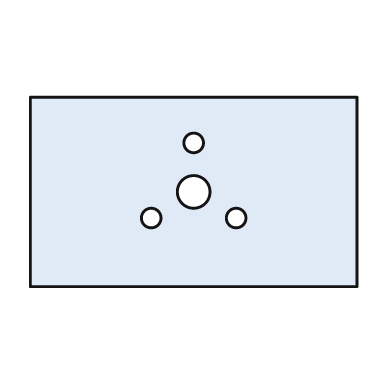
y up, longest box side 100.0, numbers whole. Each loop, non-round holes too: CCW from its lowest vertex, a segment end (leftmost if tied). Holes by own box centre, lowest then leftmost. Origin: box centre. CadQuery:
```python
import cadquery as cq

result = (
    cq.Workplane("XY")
    .moveTo(-50.0, -29.0)
    .lineTo(50.0, -29.0)
    .lineTo(50.0, 29.0)
    .lineTo(-50.0, 29.0)
    .close()
    .moveTo(-13.0, -8.0)
    .circle(3.0)
    .moveTo(13.0, -8.0)
    .circle(3.0)
    .moveTo(0.0, 0.0)
    .circle(5.0)
    .moveTo(0.0, 15.0)
    .circle(3.0)
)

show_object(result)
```